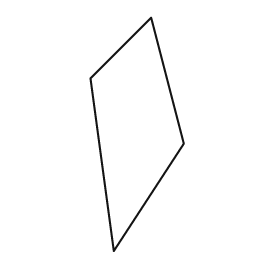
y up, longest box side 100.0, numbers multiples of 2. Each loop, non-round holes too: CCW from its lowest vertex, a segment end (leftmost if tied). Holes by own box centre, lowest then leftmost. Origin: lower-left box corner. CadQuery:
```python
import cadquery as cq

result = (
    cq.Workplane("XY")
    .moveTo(10.0, 0.0)
    .lineTo(40.0, 46.0)
    .lineTo(26.0, 100.0)
    .lineTo(0.0, 74.0)
    .close()
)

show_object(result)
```